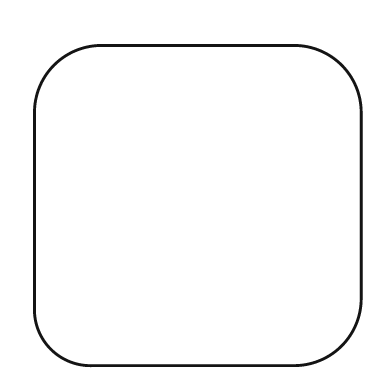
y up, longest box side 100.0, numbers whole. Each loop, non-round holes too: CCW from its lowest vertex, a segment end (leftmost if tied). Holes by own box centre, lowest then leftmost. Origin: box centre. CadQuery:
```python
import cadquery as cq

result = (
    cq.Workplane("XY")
    .moveTo(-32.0, -49.0)
    .lineTo(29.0, -49.0)
    .threePointArc((44.0, -43.0), (50.0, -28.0))
    .lineTo(50.0, 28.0)
    .threePointArc((44.0, 43.0), (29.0, 49.0))
    .lineTo(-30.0, 49.0)
    .threePointArc((-44.0, 43.0), (-50.0, 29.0))
    .lineTo(-50.0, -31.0)
    .threePointArc((-45.0, -44.0), (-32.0, -49.0))
    .close()
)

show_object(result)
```